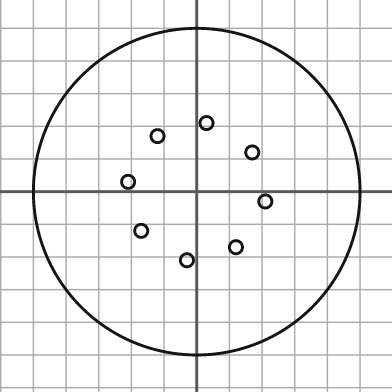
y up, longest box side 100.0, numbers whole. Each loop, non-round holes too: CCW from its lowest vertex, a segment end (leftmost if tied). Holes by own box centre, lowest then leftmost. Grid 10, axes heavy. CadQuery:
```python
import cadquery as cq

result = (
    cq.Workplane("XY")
    .moveTo(0.0, 0.0)
    .circle(50.0)
    .moveTo(-3.0, -21.0)
    .circle(2.0)
    .moveTo(12.0, -17.0)
    .circle(2.0)
    .moveTo(-17.0, -12.0)
    .circle(2.0)
    .moveTo(21.0, -3.0)
    .circle(2.0)
    .moveTo(-21.0, 3.0)
    .circle(2.0)
    .moveTo(17.0, 12.0)
    .circle(2.0)
    .moveTo(-12.0, 17.0)
    .circle(2.0)
    .moveTo(3.0, 21.0)
    .circle(2.0)
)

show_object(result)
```